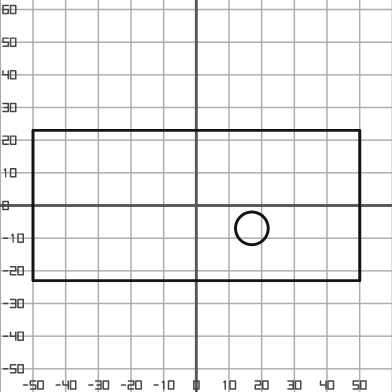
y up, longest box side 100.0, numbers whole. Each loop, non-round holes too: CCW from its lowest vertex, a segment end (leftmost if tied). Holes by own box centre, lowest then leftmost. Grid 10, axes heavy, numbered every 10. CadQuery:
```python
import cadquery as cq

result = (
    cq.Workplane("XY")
    .moveTo(-50.0, -23.0)
    .lineTo(50.0, -23.0)
    .lineTo(50.0, 23.0)
    .lineTo(-50.0, 23.0)
    .close()
    .moveTo(17.0, -7.0)
    .circle(5.0)
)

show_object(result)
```